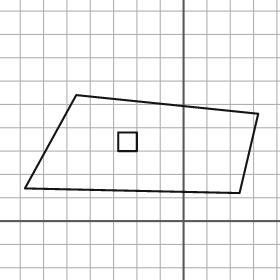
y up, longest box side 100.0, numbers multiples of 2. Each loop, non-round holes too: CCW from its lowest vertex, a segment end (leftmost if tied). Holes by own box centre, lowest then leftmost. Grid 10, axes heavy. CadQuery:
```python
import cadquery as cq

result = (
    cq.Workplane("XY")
    .moveTo(24.0, 12.0)
    .lineTo(32.0, 46.0)
    .lineTo(-46.0, 54.0)
    .lineTo(-68.0, 14.0)
    .close()
    .moveTo(-28.0, 30.0)
    .lineTo(-20.0, 30.0)
    .lineTo(-20.0, 38.0)
    .lineTo(-28.0, 38.0)
    .close()
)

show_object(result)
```